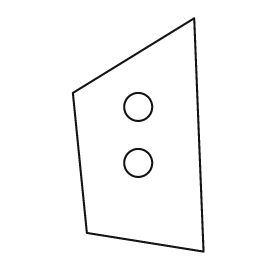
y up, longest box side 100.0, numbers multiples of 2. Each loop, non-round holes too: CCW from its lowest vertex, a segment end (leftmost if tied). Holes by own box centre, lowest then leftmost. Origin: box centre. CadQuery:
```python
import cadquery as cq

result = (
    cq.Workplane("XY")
    .moveTo(28.0, -50.0)
    .lineTo(24.0, 50.0)
    .lineTo(-28.0, 18.0)
    .lineTo(-22.0, -42.0)
    .close()
    .moveTo(0.0, -12.0)
    .circle(6.0)
    .moveTo(0.0, 12.0)
    .circle(6.0)
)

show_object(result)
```